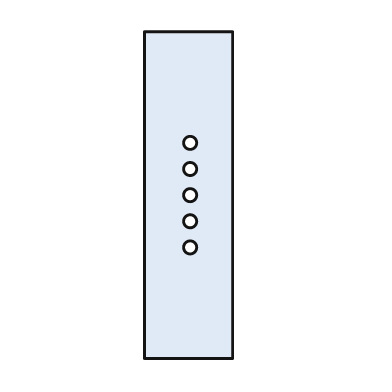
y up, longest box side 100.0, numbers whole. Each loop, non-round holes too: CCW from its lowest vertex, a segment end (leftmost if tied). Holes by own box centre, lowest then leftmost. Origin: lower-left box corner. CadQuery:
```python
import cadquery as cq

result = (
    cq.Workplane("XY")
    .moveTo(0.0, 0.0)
    .lineTo(27.0, 0.0)
    .lineTo(27.0, 100.0)
    .lineTo(0.0, 100.0)
    .close()
    .moveTo(14.0, 34.0)
    .circle(2.0)
    .moveTo(14.0, 42.0)
    .circle(2.0)
    .moveTo(14.0, 50.0)
    .circle(2.0)
    .moveTo(14.0, 58.0)
    .circle(2.0)
    .moveTo(14.0, 66.0)
    .circle(2.0)
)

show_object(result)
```